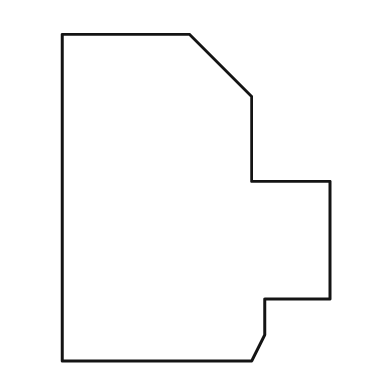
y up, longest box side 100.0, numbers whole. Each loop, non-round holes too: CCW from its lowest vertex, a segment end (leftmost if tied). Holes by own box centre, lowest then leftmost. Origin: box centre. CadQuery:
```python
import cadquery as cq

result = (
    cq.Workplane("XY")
    .moveTo(-41.0, -50.0)
    .lineTo(17.0, -50.0)
    .lineTo(21.0, -42.0)
    .lineTo(21.0, -31.0)
    .lineTo(41.0, -31.0)
    .lineTo(41.0, 5.0)
    .lineTo(17.0, 5.0)
    .lineTo(17.0, 31.0)
    .lineTo(-2.0, 50.0)
    .lineTo(-41.0, 50.0)
    .close()
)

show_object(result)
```